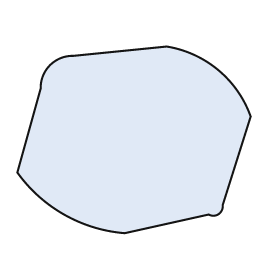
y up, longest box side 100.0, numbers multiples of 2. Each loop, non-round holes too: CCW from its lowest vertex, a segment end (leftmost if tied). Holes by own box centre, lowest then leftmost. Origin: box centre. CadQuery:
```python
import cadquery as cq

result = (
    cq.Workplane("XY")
    .moveTo(-4.0, -40.0)
    .lineTo(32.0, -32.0)
    .threePointArc((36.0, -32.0), (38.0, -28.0))
    .lineTo(50.0, 10.0)
    .threePointArc((36.0, 30.0), (14.0, 40.0))
    .lineTo(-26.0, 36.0)
    .threePointArc((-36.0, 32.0), (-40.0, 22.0))
    .lineTo(-50.0, -14.0)
    .threePointArc((-30.0, -32.0), (-4.0, -40.0))
    .close()
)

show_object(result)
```